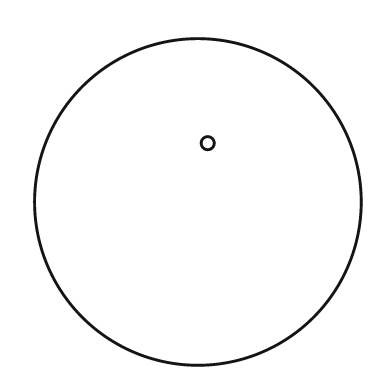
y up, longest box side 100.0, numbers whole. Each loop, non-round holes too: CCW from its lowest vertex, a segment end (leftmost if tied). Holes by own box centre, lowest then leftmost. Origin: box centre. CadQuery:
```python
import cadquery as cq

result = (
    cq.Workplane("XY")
    .moveTo(0.0, 0.0)
    .circle(50.0)
    .moveTo(3.0, 18.0)
    .circle(2.0)
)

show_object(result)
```